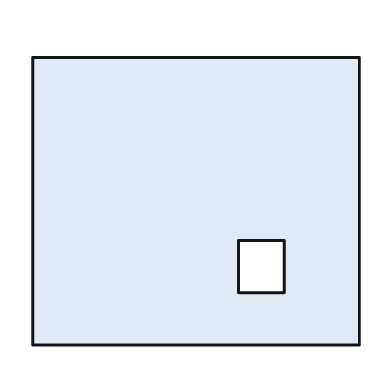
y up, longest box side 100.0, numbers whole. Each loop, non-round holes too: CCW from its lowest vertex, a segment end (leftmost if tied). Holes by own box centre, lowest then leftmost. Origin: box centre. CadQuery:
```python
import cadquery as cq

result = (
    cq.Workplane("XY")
    .moveTo(-50.0, -44.0)
    .lineTo(50.0, -44.0)
    .lineTo(50.0, 44.0)
    .lineTo(-50.0, 44.0)
    .close()
    .moveTo(13.0, -28.0)
    .lineTo(27.0, -28.0)
    .lineTo(27.0, -12.0)
    .lineTo(13.0, -12.0)
    .close()
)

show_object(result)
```